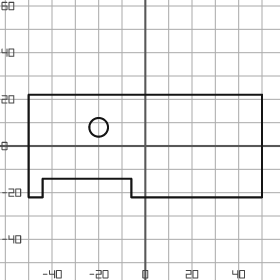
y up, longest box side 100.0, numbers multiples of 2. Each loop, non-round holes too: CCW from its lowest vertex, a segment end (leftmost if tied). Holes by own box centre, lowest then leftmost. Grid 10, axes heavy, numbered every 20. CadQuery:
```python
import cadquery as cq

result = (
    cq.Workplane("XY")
    .moveTo(-50.0, -22.0)
    .lineTo(-44.0, -22.0)
    .lineTo(-44.0, -14.0)
    .lineTo(-6.0, -14.0)
    .lineTo(-6.0, -22.0)
    .lineTo(50.0, -22.0)
    .lineTo(50.0, 22.0)
    .lineTo(-50.0, 22.0)
    .close()
    .moveTo(-20.0, 8.0)
    .circle(4.0)
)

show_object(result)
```